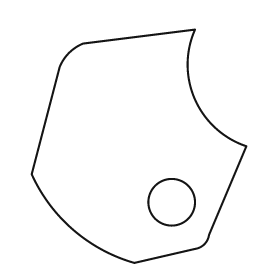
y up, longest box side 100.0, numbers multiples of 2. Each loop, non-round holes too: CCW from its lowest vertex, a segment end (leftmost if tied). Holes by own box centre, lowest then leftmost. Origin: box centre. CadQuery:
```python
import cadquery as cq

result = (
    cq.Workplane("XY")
    .moveTo(-2.0, -50.0)
    .lineTo(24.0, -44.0)
    .threePointArc((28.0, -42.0), (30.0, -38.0))
    .lineTo(46.0, 0.0)
    .threePointArc((24.0, 20.0), (24.0, 50.0))
    .lineTo(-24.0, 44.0)
    .threePointArc((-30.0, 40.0), (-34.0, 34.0))
    .lineTo(-46.0, -12.0)
    .threePointArc((-28.0, -36.0), (-2.0, -50.0))
    .close()
    .moveTo(14.0, -24.0)
    .circle(10.0)
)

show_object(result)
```